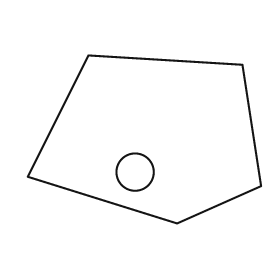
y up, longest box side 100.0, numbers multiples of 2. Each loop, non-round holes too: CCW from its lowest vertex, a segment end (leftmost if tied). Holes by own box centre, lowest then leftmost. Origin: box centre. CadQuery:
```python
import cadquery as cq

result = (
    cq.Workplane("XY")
    .moveTo(14.0, -36.0)
    .lineTo(50.0, -20.0)
    .lineTo(42.0, 32.0)
    .lineTo(-24.0, 36.0)
    .lineTo(-50.0, -16.0)
    .close()
    .moveTo(-4.0, -14.0)
    .circle(8.0)
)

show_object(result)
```